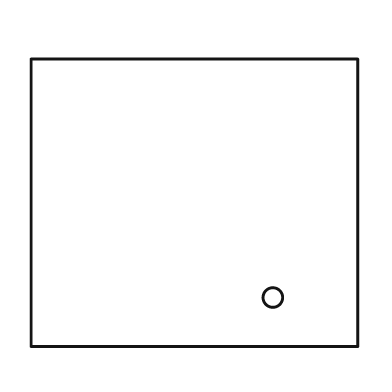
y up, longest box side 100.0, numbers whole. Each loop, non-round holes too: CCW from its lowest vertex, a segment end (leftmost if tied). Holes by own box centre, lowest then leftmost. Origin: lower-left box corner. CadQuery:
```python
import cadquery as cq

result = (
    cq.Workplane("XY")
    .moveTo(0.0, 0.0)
    .lineTo(100.0, 0.0)
    .lineTo(100.0, 88.0)
    .lineTo(0.0, 88.0)
    .close()
    .moveTo(74.0, 15.0)
    .circle(3.0)
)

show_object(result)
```